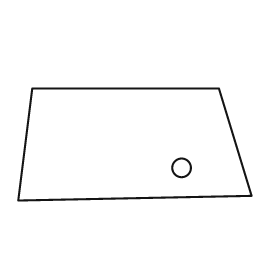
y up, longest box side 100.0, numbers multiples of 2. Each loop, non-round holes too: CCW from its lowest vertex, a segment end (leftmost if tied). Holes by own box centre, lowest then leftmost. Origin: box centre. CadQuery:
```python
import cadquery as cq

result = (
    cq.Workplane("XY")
    .moveTo(-50.0, -24.0)
    .lineTo(50.0, -22.0)
    .lineTo(36.0, 24.0)
    .lineTo(-44.0, 24.0)
    .close()
    .moveTo(20.0, -10.0)
    .circle(4.0)
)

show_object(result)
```